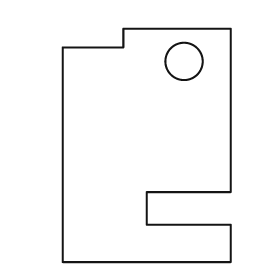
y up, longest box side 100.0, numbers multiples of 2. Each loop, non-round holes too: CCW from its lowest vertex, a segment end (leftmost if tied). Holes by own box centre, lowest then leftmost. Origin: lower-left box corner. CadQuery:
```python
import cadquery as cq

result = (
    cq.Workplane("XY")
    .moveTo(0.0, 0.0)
    .lineTo(72.0, 0.0)
    .lineTo(72.0, 16.0)
    .lineTo(36.0, 16.0)
    .lineTo(36.0, 30.0)
    .lineTo(72.0, 30.0)
    .lineTo(72.0, 100.0)
    .lineTo(26.0, 100.0)
    .lineTo(26.0, 92.0)
    .lineTo(0.0, 92.0)
    .close()
    .moveTo(52.0, 86.0)
    .circle(8.0)
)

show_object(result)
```